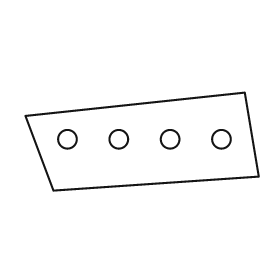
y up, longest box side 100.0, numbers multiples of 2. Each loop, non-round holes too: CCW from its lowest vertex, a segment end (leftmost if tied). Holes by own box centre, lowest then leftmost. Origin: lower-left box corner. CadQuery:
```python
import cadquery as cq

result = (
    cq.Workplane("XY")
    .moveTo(12.0, 0.0)
    .lineTo(100.0, 6.0)
    .lineTo(94.0, 42.0)
    .lineTo(0.0, 32.0)
    .close()
    .moveTo(18.0, 22.0)
    .circle(4.0)
    .moveTo(40.0, 22.0)
    .circle(4.0)
    .moveTo(62.0, 22.0)
    .circle(4.0)
    .moveTo(84.0, 22.0)
    .circle(4.0)
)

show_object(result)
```